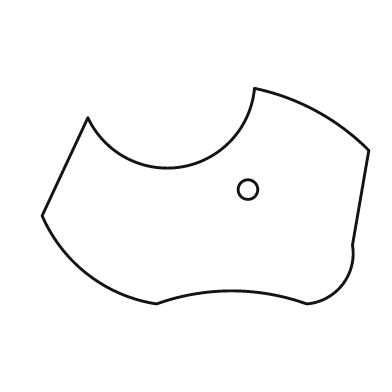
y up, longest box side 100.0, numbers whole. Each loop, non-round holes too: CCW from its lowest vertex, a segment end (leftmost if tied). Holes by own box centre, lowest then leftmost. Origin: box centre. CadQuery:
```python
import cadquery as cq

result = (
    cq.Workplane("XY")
    .moveTo(-15.0, -33.0)
    .threePointArc((8.0, -29.0), (31.0, -33.0))
    .threePointArc((42.0, -27.0), (45.0, -15.0))
    .lineTo(50.0, 14.0)
    .threePointArc((34.0, 26.0), (15.0, 33.0))
    .threePointArc((-7.0, 9.0), (-36.0, 24.0))
    .lineTo(-50.0, -6.0)
    .threePointArc((-36.0, -24.0), (-15.0, -33.0))
    .close()
    .moveTo(13.0, 2.0)
    .circle(3.0)
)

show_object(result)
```